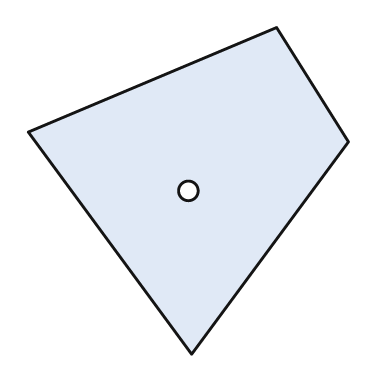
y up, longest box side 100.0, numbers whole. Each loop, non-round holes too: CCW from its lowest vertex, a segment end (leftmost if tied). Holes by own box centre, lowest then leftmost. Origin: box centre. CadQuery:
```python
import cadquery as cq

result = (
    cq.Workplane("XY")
    .moveTo(1.0, -50.0)
    .lineTo(49.0, 15.0)
    .lineTo(27.0, 50.0)
    .lineTo(-49.0, 18.0)
    .close()
    .moveTo(0.0, 0.0)
    .circle(3.0)
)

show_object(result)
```